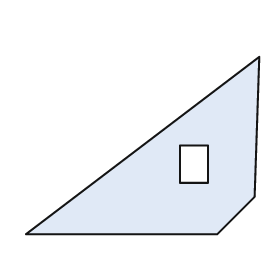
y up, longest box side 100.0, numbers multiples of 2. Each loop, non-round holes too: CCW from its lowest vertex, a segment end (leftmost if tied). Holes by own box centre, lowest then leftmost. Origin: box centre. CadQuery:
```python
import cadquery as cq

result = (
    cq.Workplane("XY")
    .moveTo(-50.0, -38.0)
    .lineTo(32.0, -38.0)
    .lineTo(48.0, -22.0)
    .lineTo(50.0, 38.0)
    .close()
    .moveTo(16.0, -16.0)
    .lineTo(28.0, -16.0)
    .lineTo(28.0, 0.0)
    .lineTo(16.0, 0.0)
    .close()
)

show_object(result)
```